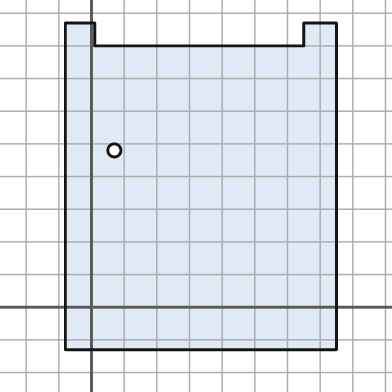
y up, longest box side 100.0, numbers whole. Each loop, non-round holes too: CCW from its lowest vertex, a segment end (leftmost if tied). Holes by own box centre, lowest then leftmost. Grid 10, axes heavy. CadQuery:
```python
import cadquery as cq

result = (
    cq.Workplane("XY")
    .moveTo(-8.0, -13.0)
    .lineTo(75.0, -13.0)
    .lineTo(75.0, 87.0)
    .lineTo(65.0, 87.0)
    .lineTo(65.0, 80.0)
    .lineTo(1.0, 80.0)
    .lineTo(1.0, 87.0)
    .lineTo(-8.0, 87.0)
    .close()
    .moveTo(7.0, 48.0)
    .circle(2.0)
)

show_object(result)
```